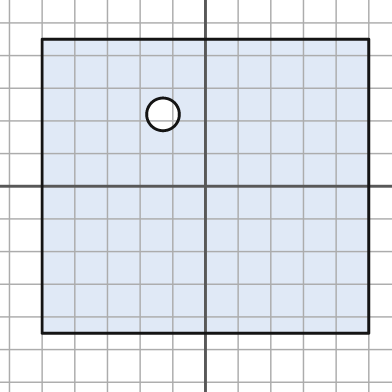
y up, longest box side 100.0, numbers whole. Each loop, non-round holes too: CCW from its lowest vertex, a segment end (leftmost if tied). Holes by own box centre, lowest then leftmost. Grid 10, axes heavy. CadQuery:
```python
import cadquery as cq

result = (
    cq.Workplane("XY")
    .moveTo(-50.0, -45.0)
    .lineTo(50.0, -45.0)
    .lineTo(50.0, 45.0)
    .lineTo(-50.0, 45.0)
    .close()
    .moveTo(-13.0, 22.0)
    .circle(5.0)
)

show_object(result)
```